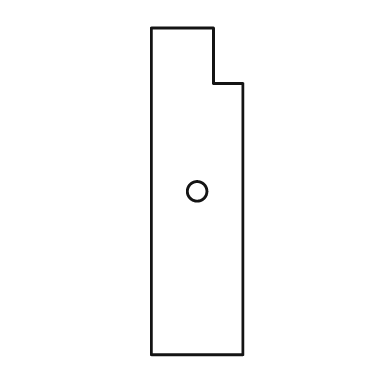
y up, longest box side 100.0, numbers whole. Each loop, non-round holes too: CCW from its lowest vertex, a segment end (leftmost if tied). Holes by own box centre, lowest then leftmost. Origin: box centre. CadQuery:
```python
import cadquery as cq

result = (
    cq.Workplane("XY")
    .moveTo(-14.0, -50.0)
    .lineTo(14.0, -50.0)
    .lineTo(14.0, 33.0)
    .lineTo(5.0, 33.0)
    .lineTo(5.0, 50.0)
    .lineTo(-14.0, 50.0)
    .close()
    .moveTo(0.0, 0.0)
    .circle(3.0)
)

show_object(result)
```